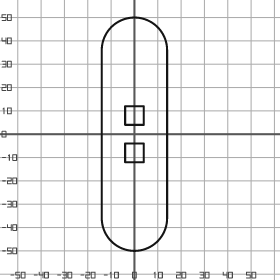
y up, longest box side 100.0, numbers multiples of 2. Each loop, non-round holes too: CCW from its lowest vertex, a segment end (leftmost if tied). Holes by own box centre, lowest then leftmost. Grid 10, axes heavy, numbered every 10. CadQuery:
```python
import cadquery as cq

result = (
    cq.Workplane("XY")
    .moveTo(-14.0, -36.0)
    .threePointArc((0.0, -50.0), (14.0, -36.0))
    .lineTo(14.0, 36.0)
    .threePointArc((0.0, 50.0), (-14.0, 36.0))
    .close()
    .moveTo(-4.0, -12.0)
    .lineTo(4.0, -12.0)
    .lineTo(4.0, -4.0)
    .lineTo(-4.0, -4.0)
    .close()
    .moveTo(-4.0, 4.0)
    .lineTo(4.0, 4.0)
    .lineTo(4.0, 12.0)
    .lineTo(-4.0, 12.0)
    .close()
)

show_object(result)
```